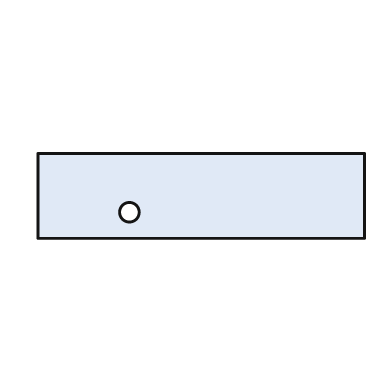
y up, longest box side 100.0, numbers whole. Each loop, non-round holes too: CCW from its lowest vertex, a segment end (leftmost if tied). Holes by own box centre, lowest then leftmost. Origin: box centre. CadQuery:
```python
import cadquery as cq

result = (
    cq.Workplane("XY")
    .moveTo(-50.0, -13.0)
    .lineTo(50.0, -13.0)
    .lineTo(50.0, 13.0)
    .lineTo(-50.0, 13.0)
    .close()
    .moveTo(-22.0, -5.0)
    .circle(3.0)
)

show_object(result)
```